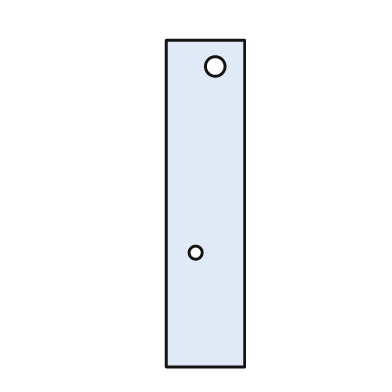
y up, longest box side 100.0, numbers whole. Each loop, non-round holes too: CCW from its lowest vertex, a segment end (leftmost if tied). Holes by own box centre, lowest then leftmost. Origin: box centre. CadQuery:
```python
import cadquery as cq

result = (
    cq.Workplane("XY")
    .moveTo(-12.0, -50.0)
    .lineTo(12.0, -50.0)
    .lineTo(12.0, 50.0)
    .lineTo(-12.0, 50.0)
    .close()
    .moveTo(-3.0, -15.0)
    .circle(2.0)
    .moveTo(3.0, 42.0)
    .circle(3.0)
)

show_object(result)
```